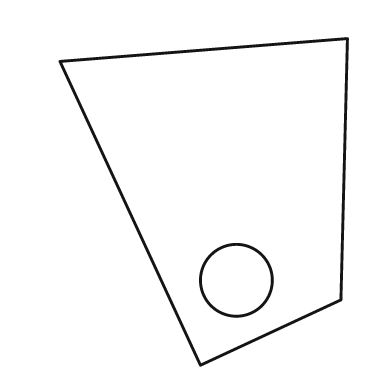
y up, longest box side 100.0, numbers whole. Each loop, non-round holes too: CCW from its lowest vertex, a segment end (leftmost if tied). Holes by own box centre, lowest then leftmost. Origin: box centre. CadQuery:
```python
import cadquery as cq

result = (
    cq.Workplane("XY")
    .moveTo(-1.0, -50.0)
    .lineTo(42.0, -30.0)
    .lineTo(44.0, 50.0)
    .lineTo(-44.0, 43.0)
    .close()
    .moveTo(10.0, -24.0)
    .circle(11.0)
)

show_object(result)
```